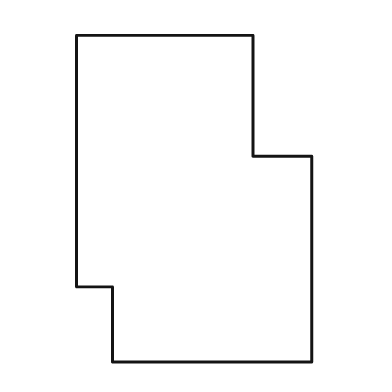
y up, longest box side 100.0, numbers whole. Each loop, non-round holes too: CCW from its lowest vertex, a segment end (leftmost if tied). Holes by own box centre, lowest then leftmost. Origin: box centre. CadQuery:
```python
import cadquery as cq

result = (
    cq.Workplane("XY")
    .moveTo(-25.0, -50.0)
    .lineTo(36.0, -50.0)
    .lineTo(36.0, 13.0)
    .lineTo(18.0, 13.0)
    .lineTo(18.0, 50.0)
    .lineTo(-36.0, 50.0)
    .lineTo(-36.0, -27.0)
    .lineTo(-25.0, -27.0)
    .close()
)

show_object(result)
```